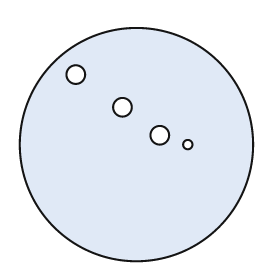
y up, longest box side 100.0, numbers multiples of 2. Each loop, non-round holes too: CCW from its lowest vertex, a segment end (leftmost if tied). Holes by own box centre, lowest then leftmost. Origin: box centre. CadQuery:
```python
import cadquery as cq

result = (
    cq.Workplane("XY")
    .moveTo(0.0, 0.0)
    .circle(50.0)
    .moveTo(22.0, 0.0)
    .circle(2.0)
    .moveTo(10.0, 4.0)
    .circle(4.0)
    .moveTo(-6.0, 16.0)
    .circle(4.0)
    .moveTo(-26.0, 30.0)
    .circle(4.0)
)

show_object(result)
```